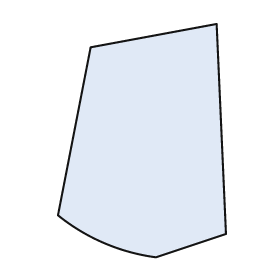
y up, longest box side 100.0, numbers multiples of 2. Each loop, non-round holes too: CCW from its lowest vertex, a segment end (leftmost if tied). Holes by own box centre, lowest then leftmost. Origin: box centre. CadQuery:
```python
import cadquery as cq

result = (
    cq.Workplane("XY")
    .moveTo(6.0, -50.0)
    .lineTo(36.0, -40.0)
    .lineTo(32.0, 50.0)
    .lineTo(-22.0, 40.0)
    .lineTo(-36.0, -32.0)
    .threePointArc((-16.0, -44.0), (6.0, -50.0))
    .close()
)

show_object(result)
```